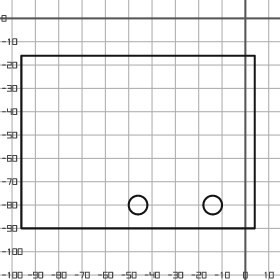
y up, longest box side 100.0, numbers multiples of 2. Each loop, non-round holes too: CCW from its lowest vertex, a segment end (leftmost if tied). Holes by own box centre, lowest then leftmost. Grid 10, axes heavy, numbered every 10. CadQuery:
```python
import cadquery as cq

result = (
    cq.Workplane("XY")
    .moveTo(-96.0, -90.0)
    .lineTo(4.0, -90.0)
    .lineTo(4.0, -16.0)
    .lineTo(-96.0, -16.0)
    .close()
    .moveTo(-46.0, -80.0)
    .circle(4.0)
    .moveTo(-14.0, -80.0)
    .circle(4.0)
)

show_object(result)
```